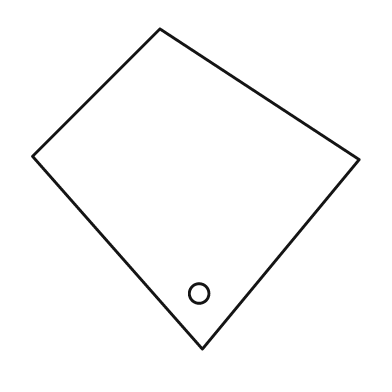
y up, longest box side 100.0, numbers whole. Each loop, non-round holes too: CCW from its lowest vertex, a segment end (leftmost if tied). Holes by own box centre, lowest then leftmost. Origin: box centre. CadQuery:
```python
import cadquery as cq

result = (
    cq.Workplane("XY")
    .moveTo(2.0, -49.0)
    .lineTo(50.0, 9.0)
    .lineTo(-11.0, 49.0)
    .lineTo(-50.0, 10.0)
    .close()
    .moveTo(1.0, -32.0)
    .circle(3.0)
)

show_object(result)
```